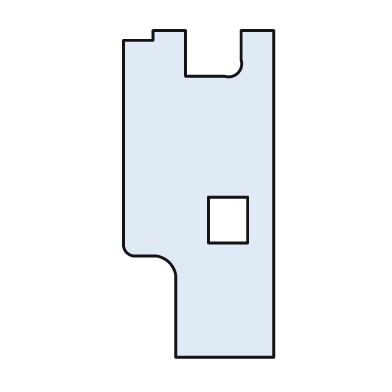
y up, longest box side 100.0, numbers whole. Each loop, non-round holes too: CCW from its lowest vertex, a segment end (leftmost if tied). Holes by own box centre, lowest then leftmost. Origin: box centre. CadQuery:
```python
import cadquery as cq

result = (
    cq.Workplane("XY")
    .moveTo(-7.0, -50.0)
    .lineTo(23.0, -50.0)
    .lineTo(23.0, 50.0)
    .lineTo(13.0, 50.0)
    .lineTo(13.0, 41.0)
    .threePointArc((12.0, 37.0), (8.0, 36.0))
    .lineTo(-4.0, 36.0)
    .lineTo(-4.0, 50.0)
    .lineTo(-14.0, 50.0)
    .lineTo(-14.0, 47.0)
    .lineTo(-23.0, 47.0)
    .lineTo(-23.0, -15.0)
    .threePointArc((-22.0, -18.0), (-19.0, -19.0))
    .lineTo(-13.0, -19.0)
    .threePointArc((-9.0, -21.0), (-7.0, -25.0))
    .close()
    .moveTo(3.0, -15.0)
    .lineTo(15.0, -15.0)
    .lineTo(15.0, -1.0)
    .lineTo(3.0, -1.0)
    .close()
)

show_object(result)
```